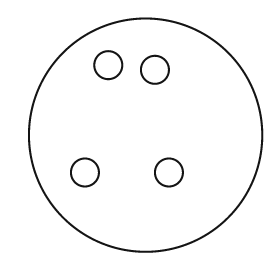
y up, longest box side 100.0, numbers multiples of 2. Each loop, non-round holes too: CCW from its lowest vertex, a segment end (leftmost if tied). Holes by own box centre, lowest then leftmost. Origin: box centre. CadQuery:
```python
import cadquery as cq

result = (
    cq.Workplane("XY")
    .moveTo(0.0, 0.0)
    .circle(50.0)
    .moveTo(-26.0, -16.0)
    .circle(6.0)
    .moveTo(10.0, -16.0)
    .circle(6.0)
    .moveTo(4.0, 28.0)
    .circle(6.0)
    .moveTo(-16.0, 30.0)
    .circle(6.0)
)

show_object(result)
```